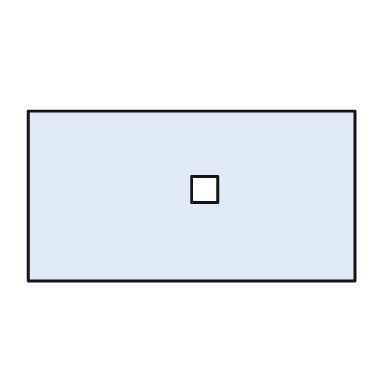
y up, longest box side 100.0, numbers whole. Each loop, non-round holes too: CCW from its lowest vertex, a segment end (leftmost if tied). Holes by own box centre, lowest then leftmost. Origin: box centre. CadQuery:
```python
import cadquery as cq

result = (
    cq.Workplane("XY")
    .moveTo(-50.0, -26.0)
    .lineTo(50.0, -26.0)
    .lineTo(50.0, 26.0)
    .lineTo(-50.0, 26.0)
    .close()
    .moveTo(0.0, -2.0)
    .lineTo(8.0, -2.0)
    .lineTo(8.0, 6.0)
    .lineTo(0.0, 6.0)
    .close()
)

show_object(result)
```